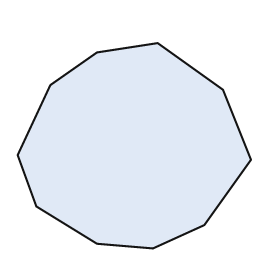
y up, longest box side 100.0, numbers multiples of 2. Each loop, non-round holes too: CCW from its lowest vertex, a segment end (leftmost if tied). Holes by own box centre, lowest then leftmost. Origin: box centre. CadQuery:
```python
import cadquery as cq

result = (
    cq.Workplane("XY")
    .moveTo(8.0, -44.0)
    .lineTo(30.0, -34.0)
    .lineTo(50.0, -6.0)
    .lineTo(38.0, 24.0)
    .lineTo(10.0, 44.0)
    .lineTo(-16.0, 40.0)
    .lineTo(-36.0, 26.0)
    .lineTo(-50.0, -4.0)
    .lineTo(-42.0, -26.0)
    .lineTo(-16.0, -42.0)
    .close()
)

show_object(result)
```